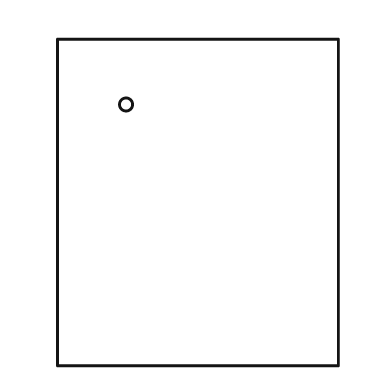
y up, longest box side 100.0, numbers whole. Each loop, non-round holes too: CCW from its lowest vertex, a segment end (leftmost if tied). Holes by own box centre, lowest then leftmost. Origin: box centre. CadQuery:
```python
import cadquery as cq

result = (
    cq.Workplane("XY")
    .moveTo(-43.0, -50.0)
    .lineTo(43.0, -50.0)
    .lineTo(43.0, 50.0)
    .lineTo(-43.0, 50.0)
    .close()
    .moveTo(-22.0, 30.0)
    .circle(2.0)
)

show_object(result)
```